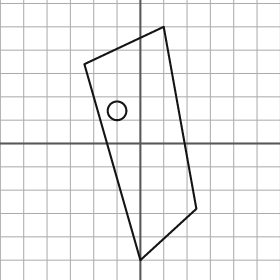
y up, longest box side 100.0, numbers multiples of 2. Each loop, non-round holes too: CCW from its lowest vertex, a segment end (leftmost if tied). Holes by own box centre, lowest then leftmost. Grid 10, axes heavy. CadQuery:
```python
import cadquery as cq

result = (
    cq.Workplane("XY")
    .moveTo(0.0, -50.0)
    .lineTo(24.0, -28.0)
    .lineTo(10.0, 50.0)
    .lineTo(-24.0, 34.0)
    .close()
    .moveTo(-10.0, 14.0)
    .circle(4.0)
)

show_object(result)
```